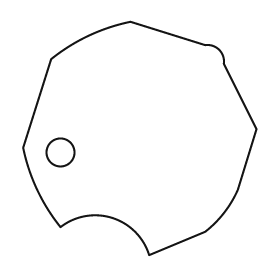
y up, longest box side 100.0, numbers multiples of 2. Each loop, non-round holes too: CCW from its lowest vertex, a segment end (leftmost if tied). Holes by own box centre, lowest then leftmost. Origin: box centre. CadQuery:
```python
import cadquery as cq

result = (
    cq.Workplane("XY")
    .moveTo(4.0, -50.0)
    .lineTo(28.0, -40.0)
    .threePointArc((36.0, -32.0), (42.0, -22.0))
    .lineTo(50.0, 4.0)
    .lineTo(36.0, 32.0)
    .threePointArc((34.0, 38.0), (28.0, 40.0))
    .lineTo(-4.0, 50.0)
    .threePointArc((-22.0, 44.0), (-38.0, 34.0))
    .lineTo(-50.0, -4.0)
    .threePointArc((-44.0, -22.0), (-34.0, -38.0))
    .threePointArc((-12.0, -34.0), (4.0, -50.0))
    .close()
    .moveTo(-34.0, -6.0)
    .circle(6.0)
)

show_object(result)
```